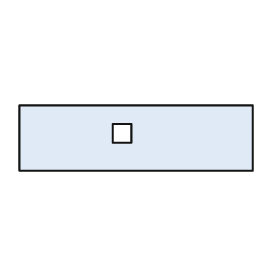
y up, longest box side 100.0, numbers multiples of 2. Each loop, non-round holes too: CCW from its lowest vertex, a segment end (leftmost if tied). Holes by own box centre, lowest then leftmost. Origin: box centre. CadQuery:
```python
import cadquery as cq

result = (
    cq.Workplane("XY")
    .moveTo(-50.0, -14.0)
    .lineTo(50.0, -14.0)
    .lineTo(50.0, 14.0)
    .lineTo(-50.0, 14.0)
    .close()
    .moveTo(-10.0, -2.0)
    .lineTo(-2.0, -2.0)
    .lineTo(-2.0, 6.0)
    .lineTo(-10.0, 6.0)
    .close()
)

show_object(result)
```